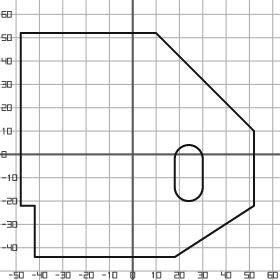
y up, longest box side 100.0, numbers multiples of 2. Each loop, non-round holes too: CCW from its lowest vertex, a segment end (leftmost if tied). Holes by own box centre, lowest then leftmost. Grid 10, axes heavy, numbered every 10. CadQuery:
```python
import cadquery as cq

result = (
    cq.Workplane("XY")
    .moveTo(-42.0, -44.0)
    .lineTo(18.0, -44.0)
    .lineTo(52.0, -22.0)
    .lineTo(52.0, 10.0)
    .lineTo(10.0, 52.0)
    .lineTo(-48.0, 52.0)
    .lineTo(-48.0, -22.0)
    .lineTo(-42.0, -22.0)
    .close()
    .moveTo(18.0, -14.0)
    .threePointArc((24.0, -20.0), (30.0, -14.0))
    .lineTo(30.0, -2.0)
    .threePointArc((24.0, 4.0), (18.0, -2.0))
    .close()
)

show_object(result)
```